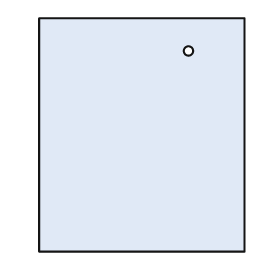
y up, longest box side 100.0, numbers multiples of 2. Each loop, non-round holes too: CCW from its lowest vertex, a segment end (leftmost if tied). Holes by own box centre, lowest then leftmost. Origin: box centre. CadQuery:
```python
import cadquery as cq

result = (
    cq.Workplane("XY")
    .moveTo(-44.0, -50.0)
    .lineTo(44.0, -50.0)
    .lineTo(44.0, 50.0)
    .lineTo(-44.0, 50.0)
    .close()
    .moveTo(20.0, 36.0)
    .circle(2.0)
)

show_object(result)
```